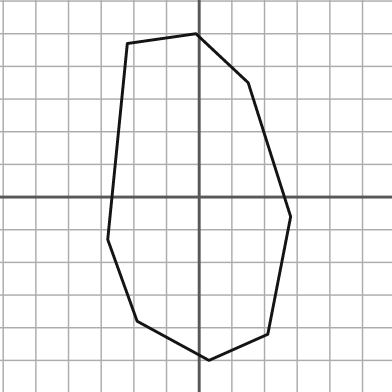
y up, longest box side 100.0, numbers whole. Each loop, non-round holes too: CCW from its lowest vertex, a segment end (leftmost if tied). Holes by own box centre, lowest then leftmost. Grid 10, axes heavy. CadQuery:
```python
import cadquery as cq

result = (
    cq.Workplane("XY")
    .moveTo(3.0, -50.0)
    .lineTo(21.0, -42.0)
    .lineTo(28.0, -6.0)
    .lineTo(15.0, 35.0)
    .lineTo(-1.0, 50.0)
    .lineTo(-22.0, 47.0)
    .lineTo(-28.0, -13.0)
    .lineTo(-19.0, -38.0)
    .close()
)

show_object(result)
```